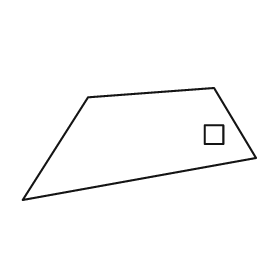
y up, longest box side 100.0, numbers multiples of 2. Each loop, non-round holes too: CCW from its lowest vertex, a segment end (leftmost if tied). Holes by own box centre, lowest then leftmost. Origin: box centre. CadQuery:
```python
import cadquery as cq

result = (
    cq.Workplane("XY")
    .moveTo(-50.0, -24.0)
    .lineTo(50.0, -6.0)
    .lineTo(32.0, 24.0)
    .lineTo(-22.0, 20.0)
    .close()
    .moveTo(28.0, 0.0)
    .lineTo(36.0, 0.0)
    .lineTo(36.0, 8.0)
    .lineTo(28.0, 8.0)
    .close()
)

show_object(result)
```